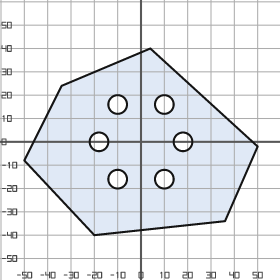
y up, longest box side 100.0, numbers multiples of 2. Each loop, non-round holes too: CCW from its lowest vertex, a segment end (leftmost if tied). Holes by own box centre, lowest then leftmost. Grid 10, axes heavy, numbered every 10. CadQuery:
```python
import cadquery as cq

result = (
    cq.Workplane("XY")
    .moveTo(-20.0, -40.0)
    .lineTo(36.0, -34.0)
    .lineTo(50.0, -2.0)
    .lineTo(4.0, 40.0)
    .lineTo(-34.0, 24.0)
    .lineTo(-50.0, -8.0)
    .close()
    .moveTo(-10.0, -16.0)
    .circle(4.0)
    .moveTo(10.0, -16.0)
    .circle(4.0)
    .moveTo(-18.0, 0.0)
    .circle(4.0)
    .moveTo(18.0, 0.0)
    .circle(4.0)
    .moveTo(-10.0, 16.0)
    .circle(4.0)
    .moveTo(10.0, 16.0)
    .circle(4.0)
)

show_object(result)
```